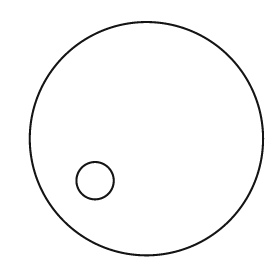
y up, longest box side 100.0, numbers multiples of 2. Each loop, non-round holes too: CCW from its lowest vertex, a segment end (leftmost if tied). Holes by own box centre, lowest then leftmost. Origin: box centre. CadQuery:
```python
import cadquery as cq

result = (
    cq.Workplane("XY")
    .moveTo(0.0, 0.0)
    .circle(50.0)
    .moveTo(-22.0, -18.0)
    .circle(8.0)
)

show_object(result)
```